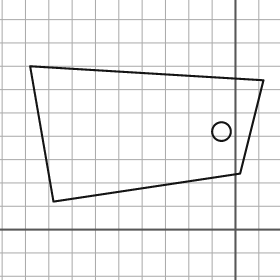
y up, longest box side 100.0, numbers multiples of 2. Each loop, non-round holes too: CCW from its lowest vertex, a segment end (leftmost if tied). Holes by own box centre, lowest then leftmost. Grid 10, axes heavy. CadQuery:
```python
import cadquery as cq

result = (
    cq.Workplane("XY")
    .moveTo(-78.0, 12.0)
    .lineTo(2.0, 24.0)
    .lineTo(12.0, 64.0)
    .lineTo(-88.0, 70.0)
    .close()
    .moveTo(-6.0, 42.0)
    .circle(4.0)
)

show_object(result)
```